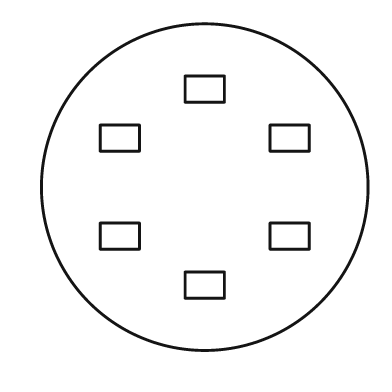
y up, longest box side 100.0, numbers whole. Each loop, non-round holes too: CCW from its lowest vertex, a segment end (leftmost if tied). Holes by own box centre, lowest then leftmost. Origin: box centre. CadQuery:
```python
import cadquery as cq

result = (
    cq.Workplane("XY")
    .moveTo(0.0, 0.0)
    .circle(50.0)
    .moveTo(-6.0, -34.0)
    .lineTo(6.0, -34.0)
    .lineTo(6.0, -26.0)
    .lineTo(-6.0, -26.0)
    .close()
    .moveTo(-32.0, -19.0)
    .lineTo(-20.0, -19.0)
    .lineTo(-20.0, -11.0)
    .lineTo(-32.0, -11.0)
    .close()
    .moveTo(20.0, -19.0)
    .lineTo(32.0, -19.0)
    .lineTo(32.0, -11.0)
    .lineTo(20.0, -11.0)
    .close()
    .moveTo(-32.0, 11.0)
    .lineTo(-20.0, 11.0)
    .lineTo(-20.0, 19.0)
    .lineTo(-32.0, 19.0)
    .close()
    .moveTo(20.0, 11.0)
    .lineTo(32.0, 11.0)
    .lineTo(32.0, 19.0)
    .lineTo(20.0, 19.0)
    .close()
    .moveTo(-6.0, 26.0)
    .lineTo(6.0, 26.0)
    .lineTo(6.0, 34.0)
    .lineTo(-6.0, 34.0)
    .close()
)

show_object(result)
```